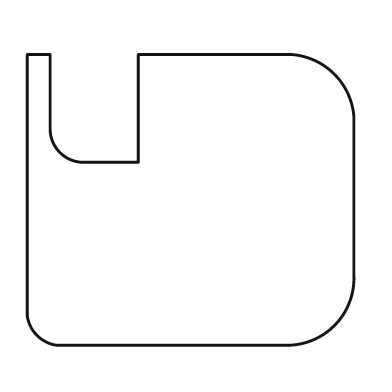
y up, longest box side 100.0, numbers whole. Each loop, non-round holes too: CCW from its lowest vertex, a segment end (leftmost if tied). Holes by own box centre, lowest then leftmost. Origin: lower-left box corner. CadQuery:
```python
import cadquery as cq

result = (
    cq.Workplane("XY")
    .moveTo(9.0, 0.0)
    .lineTo(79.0, 0.0)
    .threePointArc((94.0, 6.0), (100.0, 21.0))
    .lineTo(100.0, 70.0)
    .threePointArc((94.0, 83.0), (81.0, 89.0))
    .lineTo(34.0, 89.0)
    .lineTo(34.0, 56.0)
    .lineTo(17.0, 56.0)
    .threePointArc((10.0, 59.0), (7.0, 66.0))
    .lineTo(7.0, 89.0)
    .lineTo(0.0, 89.0)
    .lineTo(0.0, 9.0)
    .threePointArc((3.0, 3.0), (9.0, 0.0))
    .close()
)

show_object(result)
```